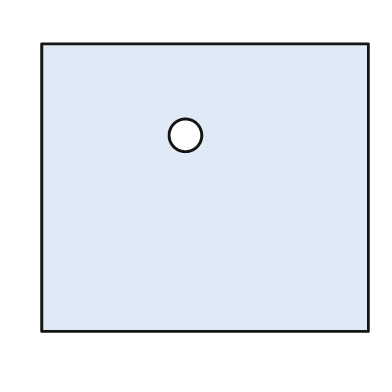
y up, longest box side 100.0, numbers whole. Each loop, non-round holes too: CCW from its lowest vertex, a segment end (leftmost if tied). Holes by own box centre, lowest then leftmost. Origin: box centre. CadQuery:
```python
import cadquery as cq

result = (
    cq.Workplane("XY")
    .moveTo(-50.0, -44.0)
    .lineTo(50.0, -44.0)
    .lineTo(50.0, 44.0)
    .lineTo(-50.0, 44.0)
    .close()
    .moveTo(-6.0, 16.0)
    .circle(5.0)
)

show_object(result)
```